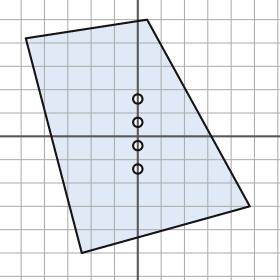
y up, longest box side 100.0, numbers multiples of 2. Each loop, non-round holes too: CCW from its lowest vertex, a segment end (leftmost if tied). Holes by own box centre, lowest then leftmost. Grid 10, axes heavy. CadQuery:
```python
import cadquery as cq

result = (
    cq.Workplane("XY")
    .moveTo(-24.0, -50.0)
    .lineTo(48.0, -30.0)
    .lineTo(4.0, 50.0)
    .lineTo(-48.0, 42.0)
    .close()
    .moveTo(0.0, -14.0)
    .circle(2.0)
    .moveTo(0.0, -4.0)
    .circle(2.0)
    .moveTo(0.0, 6.0)
    .circle(2.0)
    .moveTo(0.0, 16.0)
    .circle(2.0)
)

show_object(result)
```